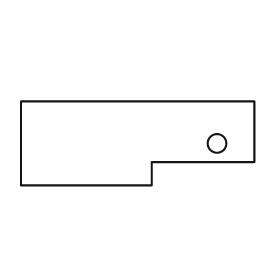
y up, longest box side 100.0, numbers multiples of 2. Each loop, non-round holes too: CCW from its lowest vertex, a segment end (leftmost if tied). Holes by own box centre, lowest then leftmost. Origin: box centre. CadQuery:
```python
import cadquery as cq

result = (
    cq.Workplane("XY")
    .moveTo(-50.0, -18.0)
    .lineTo(6.0, -18.0)
    .lineTo(6.0, -8.0)
    .lineTo(50.0, -8.0)
    .lineTo(50.0, 18.0)
    .lineTo(-50.0, 18.0)
    .close()
    .moveTo(34.0, 0.0)
    .circle(4.0)
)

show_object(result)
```